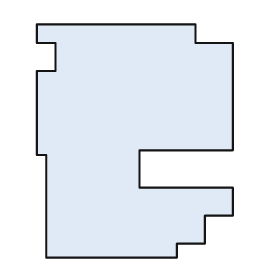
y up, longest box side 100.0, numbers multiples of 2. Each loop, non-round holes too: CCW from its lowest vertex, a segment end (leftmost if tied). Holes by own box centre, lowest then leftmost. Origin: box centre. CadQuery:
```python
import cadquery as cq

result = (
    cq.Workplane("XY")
    .moveTo(-38.0, -50.0)
    .lineTo(18.0, -50.0)
    .lineTo(18.0, -44.0)
    .lineTo(30.0, -44.0)
    .lineTo(30.0, -32.0)
    .lineTo(42.0, -32.0)
    .lineTo(42.0, -20.0)
    .lineTo(2.0, -20.0)
    .lineTo(2.0, -4.0)
    .lineTo(42.0, -4.0)
    .lineTo(42.0, 42.0)
    .lineTo(26.0, 42.0)
    .lineTo(26.0, 50.0)
    .lineTo(-42.0, 50.0)
    .lineTo(-42.0, 42.0)
    .lineTo(-34.0, 42.0)
    .lineTo(-34.0, 30.0)
    .lineTo(-42.0, 30.0)
    .lineTo(-42.0, -6.0)
    .lineTo(-38.0, -6.0)
    .close()
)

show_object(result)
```